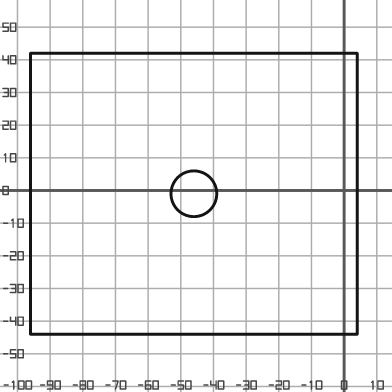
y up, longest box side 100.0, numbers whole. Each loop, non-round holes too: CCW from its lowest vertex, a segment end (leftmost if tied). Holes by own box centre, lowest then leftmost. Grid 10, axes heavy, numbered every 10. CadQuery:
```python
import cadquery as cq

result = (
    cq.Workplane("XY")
    .moveTo(-96.0, -44.0)
    .lineTo(4.0, -44.0)
    .lineTo(4.0, 42.0)
    .lineTo(-96.0, 42.0)
    .close()
    .moveTo(-46.0, -1.0)
    .circle(7.0)
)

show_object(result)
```